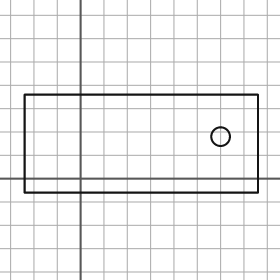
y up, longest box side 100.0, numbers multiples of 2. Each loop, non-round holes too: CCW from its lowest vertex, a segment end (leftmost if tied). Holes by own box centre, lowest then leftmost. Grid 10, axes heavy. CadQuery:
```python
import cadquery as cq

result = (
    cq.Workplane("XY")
    .moveTo(-24.0, -6.0)
    .lineTo(76.0, -6.0)
    .lineTo(76.0, 36.0)
    .lineTo(-24.0, 36.0)
    .close()
    .moveTo(60.0, 18.0)
    .circle(4.0)
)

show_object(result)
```